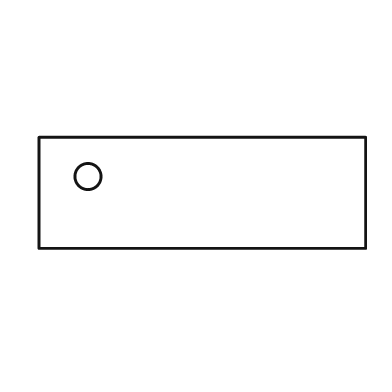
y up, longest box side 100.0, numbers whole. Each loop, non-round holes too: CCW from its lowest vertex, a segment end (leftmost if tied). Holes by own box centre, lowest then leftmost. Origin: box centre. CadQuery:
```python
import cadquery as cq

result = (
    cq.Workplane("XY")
    .moveTo(-50.0, -17.0)
    .lineTo(50.0, -17.0)
    .lineTo(50.0, 17.0)
    .lineTo(-50.0, 17.0)
    .close()
    .moveTo(-35.0, 5.0)
    .circle(4.0)
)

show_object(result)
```